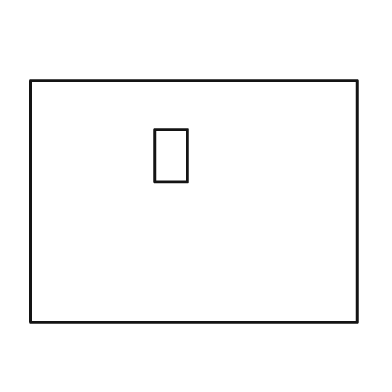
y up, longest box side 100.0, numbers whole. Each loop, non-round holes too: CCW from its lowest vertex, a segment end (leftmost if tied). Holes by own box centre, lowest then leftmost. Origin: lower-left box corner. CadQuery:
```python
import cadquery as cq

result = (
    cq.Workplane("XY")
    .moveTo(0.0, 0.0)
    .lineTo(100.0, 0.0)
    .lineTo(100.0, 74.0)
    .lineTo(0.0, 74.0)
    .close()
    .moveTo(38.0, 43.0)
    .lineTo(48.0, 43.0)
    .lineTo(48.0, 59.0)
    .lineTo(38.0, 59.0)
    .close()
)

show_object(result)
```